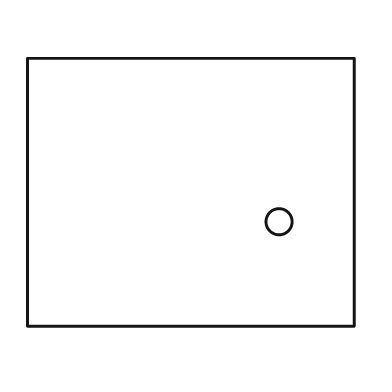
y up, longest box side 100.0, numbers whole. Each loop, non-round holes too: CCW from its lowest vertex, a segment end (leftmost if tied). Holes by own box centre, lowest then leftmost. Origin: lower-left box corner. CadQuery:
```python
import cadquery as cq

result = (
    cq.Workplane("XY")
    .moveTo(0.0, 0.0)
    .lineTo(100.0, 0.0)
    .lineTo(100.0, 82.0)
    .lineTo(0.0, 82.0)
    .close()
    .moveTo(77.0, 32.0)
    .circle(4.0)
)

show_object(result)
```